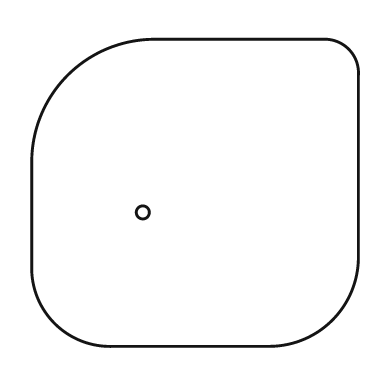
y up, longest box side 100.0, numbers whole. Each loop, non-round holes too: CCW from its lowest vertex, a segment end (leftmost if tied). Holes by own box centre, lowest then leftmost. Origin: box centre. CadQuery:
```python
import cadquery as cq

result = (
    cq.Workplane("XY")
    .moveTo(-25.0, -47.0)
    .lineTo(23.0, -47.0)
    .threePointArc((42.0, -39.0), (50.0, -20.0))
    .lineTo(50.0, 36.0)
    .threePointArc((47.0, 44.0), (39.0, 47.0))
    .lineTo(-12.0, 47.0)
    .threePointArc((-39.0, 36.0), (-50.0, 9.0))
    .lineTo(-50.0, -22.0)
    .threePointArc((-43.0, -40.0), (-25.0, -47.0))
    .close()
    .moveTo(-16.0, -6.0)
    .circle(2.0)
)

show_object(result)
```